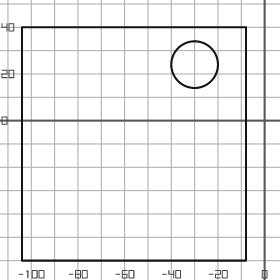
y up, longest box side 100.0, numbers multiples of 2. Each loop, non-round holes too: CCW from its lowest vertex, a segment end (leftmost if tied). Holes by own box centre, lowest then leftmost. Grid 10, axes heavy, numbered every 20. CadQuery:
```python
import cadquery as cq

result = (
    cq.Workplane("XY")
    .moveTo(-104.0, -60.0)
    .lineTo(-8.0, -60.0)
    .lineTo(-8.0, 40.0)
    .lineTo(-104.0, 40.0)
    .close()
    .moveTo(-30.0, 24.0)
    .circle(10.0)
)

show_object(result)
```